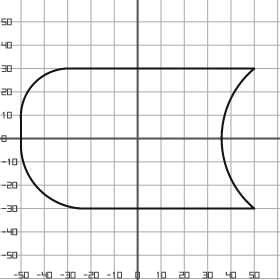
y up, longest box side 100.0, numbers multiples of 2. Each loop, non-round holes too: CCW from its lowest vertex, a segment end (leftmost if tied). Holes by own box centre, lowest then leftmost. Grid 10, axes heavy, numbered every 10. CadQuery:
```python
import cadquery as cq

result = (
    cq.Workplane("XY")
    .moveTo(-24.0, -30.0)
    .lineTo(50.0, -30.0)
    .threePointArc((36.0, 0.0), (50.0, 30.0))
    .lineTo(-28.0, 30.0)
    .threePointArc((-44.0, 24.0), (-50.0, 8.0))
    .lineTo(-50.0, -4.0)
    .threePointArc((-42.0, -22.0), (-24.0, -30.0))
    .close()
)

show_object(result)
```